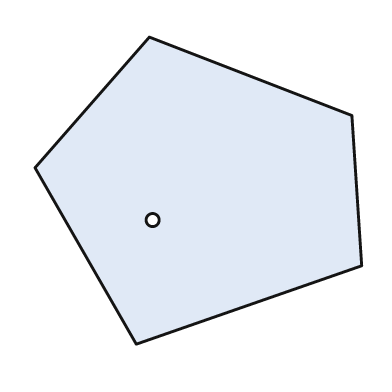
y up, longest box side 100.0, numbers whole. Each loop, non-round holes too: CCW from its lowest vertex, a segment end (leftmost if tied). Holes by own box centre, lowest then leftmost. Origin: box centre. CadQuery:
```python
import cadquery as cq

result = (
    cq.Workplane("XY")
    .moveTo(-19.0, -47.0)
    .lineTo(50.0, -23.0)
    .lineTo(47.0, 23.0)
    .lineTo(-15.0, 47.0)
    .lineTo(-50.0, 7.0)
    .close()
    .moveTo(-14.0, -9.0)
    .circle(2.0)
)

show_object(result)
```